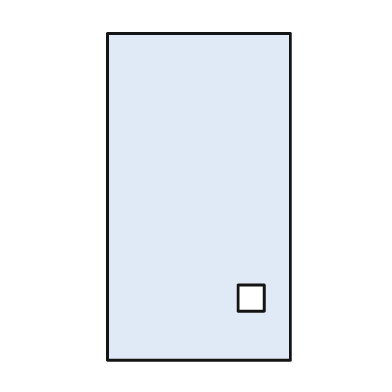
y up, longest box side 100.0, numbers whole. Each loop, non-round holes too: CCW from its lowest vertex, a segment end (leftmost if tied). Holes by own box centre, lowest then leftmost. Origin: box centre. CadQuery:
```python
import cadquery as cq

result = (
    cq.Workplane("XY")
    .moveTo(-28.0, -50.0)
    .lineTo(28.0, -50.0)
    .lineTo(28.0, 50.0)
    .lineTo(-28.0, 50.0)
    .close()
    .moveTo(12.0, -35.0)
    .lineTo(20.0, -35.0)
    .lineTo(20.0, -27.0)
    .lineTo(12.0, -27.0)
    .close()
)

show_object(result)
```